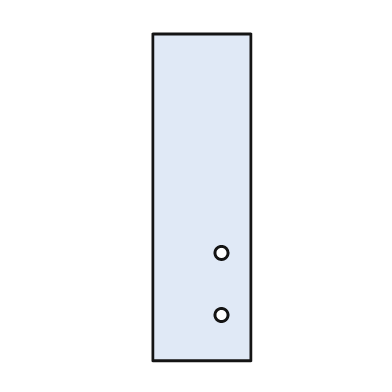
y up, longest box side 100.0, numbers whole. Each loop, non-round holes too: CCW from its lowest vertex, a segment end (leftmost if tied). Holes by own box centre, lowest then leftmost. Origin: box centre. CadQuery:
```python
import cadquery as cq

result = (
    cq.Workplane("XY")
    .moveTo(-15.0, -50.0)
    .lineTo(15.0, -50.0)
    .lineTo(15.0, 50.0)
    .lineTo(-15.0, 50.0)
    .close()
    .moveTo(6.0, -36.0)
    .circle(2.0)
    .moveTo(6.0, -17.0)
    .circle(2.0)
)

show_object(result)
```